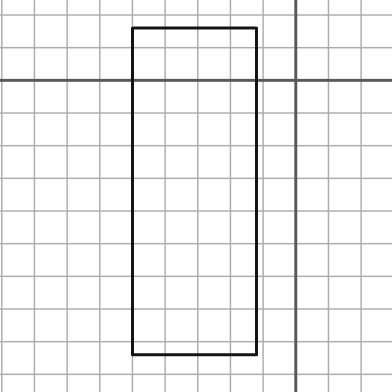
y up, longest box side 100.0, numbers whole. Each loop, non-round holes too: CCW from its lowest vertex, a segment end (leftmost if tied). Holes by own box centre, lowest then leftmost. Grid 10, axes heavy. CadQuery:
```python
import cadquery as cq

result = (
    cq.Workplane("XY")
    .moveTo(-50.0, -84.0)
    .lineTo(-12.0, -84.0)
    .lineTo(-12.0, 16.0)
    .lineTo(-50.0, 16.0)
    .close()
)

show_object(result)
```